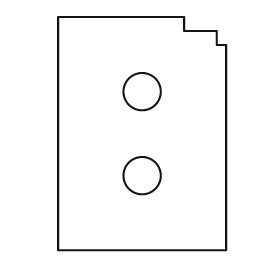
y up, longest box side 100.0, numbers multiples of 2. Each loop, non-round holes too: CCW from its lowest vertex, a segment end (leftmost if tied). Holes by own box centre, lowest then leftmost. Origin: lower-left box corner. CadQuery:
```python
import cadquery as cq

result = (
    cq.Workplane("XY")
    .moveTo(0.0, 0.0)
    .lineTo(72.0, 0.0)
    .lineTo(72.0, 88.0)
    .lineTo(68.0, 88.0)
    .lineTo(68.0, 94.0)
    .lineTo(54.0, 94.0)
    .lineTo(54.0, 100.0)
    .lineTo(0.0, 100.0)
    .close()
    .moveTo(36.0, 32.0)
    .circle(8.0)
    .moveTo(36.0, 68.0)
    .circle(8.0)
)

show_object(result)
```